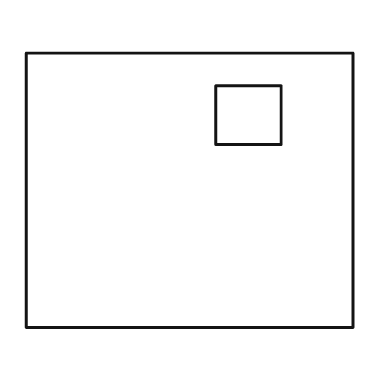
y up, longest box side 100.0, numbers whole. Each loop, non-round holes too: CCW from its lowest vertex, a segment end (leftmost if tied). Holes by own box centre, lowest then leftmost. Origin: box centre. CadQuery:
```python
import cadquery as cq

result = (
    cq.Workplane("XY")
    .moveTo(-50.0, -42.0)
    .lineTo(50.0, -42.0)
    .lineTo(50.0, 42.0)
    .lineTo(-50.0, 42.0)
    .close()
    .moveTo(8.0, 14.0)
    .lineTo(28.0, 14.0)
    .lineTo(28.0, 32.0)
    .lineTo(8.0, 32.0)
    .close()
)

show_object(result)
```